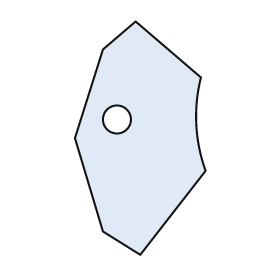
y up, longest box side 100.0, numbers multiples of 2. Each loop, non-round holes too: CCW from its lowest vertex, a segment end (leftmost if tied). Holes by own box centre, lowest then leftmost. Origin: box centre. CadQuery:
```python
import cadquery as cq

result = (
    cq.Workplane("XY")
    .moveTo(0.0, -50.0)
    .lineTo(28.0, -14.0)
    .threePointArc((24.0, 6.0), (26.0, 26.0))
    .lineTo(-2.0, 50.0)
    .lineTo(-16.0, 38.0)
    .lineTo(-28.0, 0.0)
    .lineTo(-16.0, -40.0)
    .close()
    .moveTo(-10.0, 8.0)
    .circle(6.0)
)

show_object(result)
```